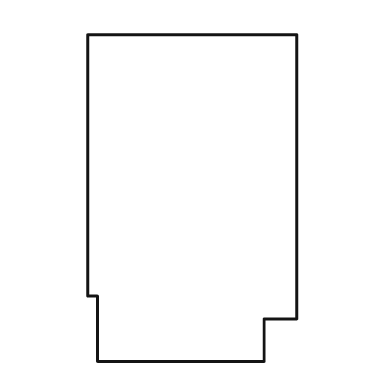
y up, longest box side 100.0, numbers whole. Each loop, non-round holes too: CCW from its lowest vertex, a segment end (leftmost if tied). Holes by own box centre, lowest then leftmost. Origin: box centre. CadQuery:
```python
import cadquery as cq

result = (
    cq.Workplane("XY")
    .moveTo(-29.0, -50.0)
    .lineTo(22.0, -50.0)
    .lineTo(22.0, -37.0)
    .lineTo(32.0, -37.0)
    .lineTo(32.0, 50.0)
    .lineTo(-32.0, 50.0)
    .lineTo(-32.0, -30.0)
    .lineTo(-29.0, -30.0)
    .close()
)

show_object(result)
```